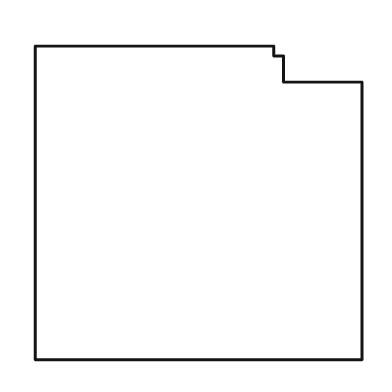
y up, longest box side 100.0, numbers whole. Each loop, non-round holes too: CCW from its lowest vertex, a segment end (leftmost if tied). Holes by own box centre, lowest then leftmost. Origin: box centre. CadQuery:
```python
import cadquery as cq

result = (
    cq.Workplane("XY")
    .moveTo(-50.0, -48.0)
    .lineTo(50.0, -48.0)
    .lineTo(50.0, 37.0)
    .lineTo(26.0, 37.0)
    .lineTo(26.0, 45.0)
    .lineTo(23.0, 45.0)
    .lineTo(23.0, 48.0)
    .lineTo(-50.0, 48.0)
    .close()
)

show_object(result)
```